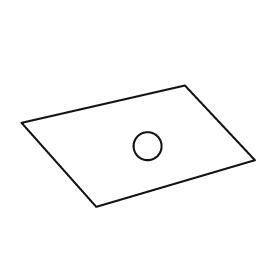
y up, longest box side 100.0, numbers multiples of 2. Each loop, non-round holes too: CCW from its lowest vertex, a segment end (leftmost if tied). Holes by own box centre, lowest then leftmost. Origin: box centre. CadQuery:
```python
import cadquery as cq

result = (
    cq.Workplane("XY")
    .moveTo(-18.0, -26.0)
    .lineTo(50.0, -6.0)
    .lineTo(20.0, 26.0)
    .lineTo(-50.0, 10.0)
    .close()
    .moveTo(4.0, 0.0)
    .circle(6.0)
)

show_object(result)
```